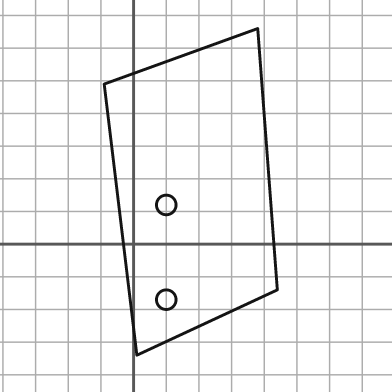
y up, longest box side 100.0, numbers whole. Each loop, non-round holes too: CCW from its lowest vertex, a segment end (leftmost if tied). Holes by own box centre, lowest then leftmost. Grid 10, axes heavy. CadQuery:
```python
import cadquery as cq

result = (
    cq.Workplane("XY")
    .moveTo(1.0, -34.0)
    .lineTo(44.0, -14.0)
    .lineTo(38.0, 66.0)
    .lineTo(-9.0, 49.0)
    .close()
    .moveTo(10.0, -17.0)
    .circle(3.0)
    .moveTo(10.0, 12.0)
    .circle(3.0)
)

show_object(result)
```